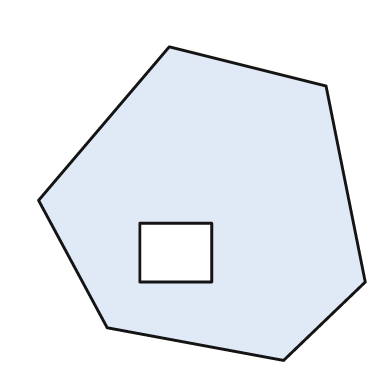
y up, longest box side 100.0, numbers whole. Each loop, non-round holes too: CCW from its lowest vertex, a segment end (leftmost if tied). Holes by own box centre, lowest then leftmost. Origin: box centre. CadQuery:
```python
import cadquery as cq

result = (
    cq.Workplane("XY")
    .moveTo(25.0, -48.0)
    .lineTo(50.0, -24.0)
    .lineTo(38.0, 36.0)
    .lineTo(-10.0, 48.0)
    .lineTo(-50.0, 1.0)
    .lineTo(-29.0, -38.0)
    .close()
    .moveTo(-19.0, -24.0)
    .lineTo(3.0, -24.0)
    .lineTo(3.0, -6.0)
    .lineTo(-19.0, -6.0)
    .close()
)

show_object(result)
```